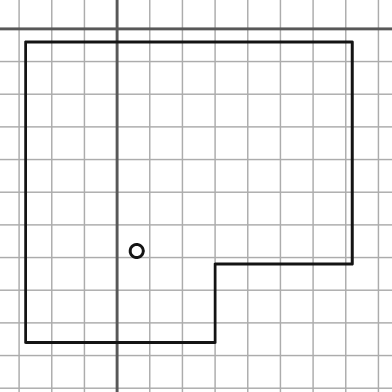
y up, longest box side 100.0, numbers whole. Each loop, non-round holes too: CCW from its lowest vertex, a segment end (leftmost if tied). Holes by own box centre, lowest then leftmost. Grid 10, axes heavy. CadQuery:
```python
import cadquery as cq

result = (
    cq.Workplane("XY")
    .moveTo(-28.0, -96.0)
    .lineTo(30.0, -96.0)
    .lineTo(30.0, -72.0)
    .lineTo(72.0, -72.0)
    .lineTo(72.0, -4.0)
    .lineTo(-28.0, -4.0)
    .close()
    .moveTo(6.0, -68.0)
    .circle(2.0)
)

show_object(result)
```